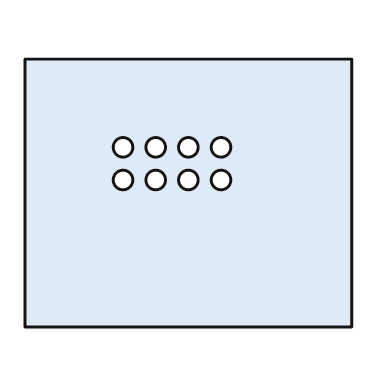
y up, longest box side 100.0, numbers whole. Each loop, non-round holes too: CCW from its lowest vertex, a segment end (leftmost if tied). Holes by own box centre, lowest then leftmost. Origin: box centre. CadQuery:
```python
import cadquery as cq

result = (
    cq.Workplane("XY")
    .moveTo(-50.0, -41.0)
    .lineTo(50.0, -41.0)
    .lineTo(50.0, 41.0)
    .lineTo(-50.0, 41.0)
    .close()
    .moveTo(-20.0, 4.0)
    .circle(3.0)
    .moveTo(-10.0, 4.0)
    .circle(3.0)
    .moveTo(0.0, 4.0)
    .circle(3.0)
    .moveTo(10.0, 4.0)
    .circle(3.0)
    .moveTo(-20.0, 14.0)
    .circle(3.0)
    .moveTo(-10.0, 14.0)
    .circle(3.0)
    .moveTo(0.0, 14.0)
    .circle(3.0)
    .moveTo(10.0, 14.0)
    .circle(3.0)
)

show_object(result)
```